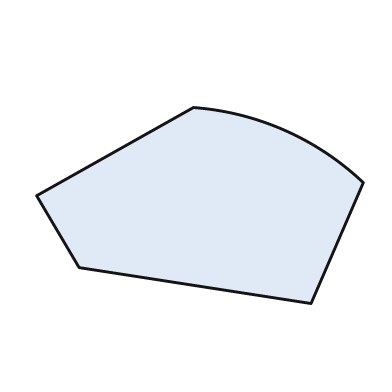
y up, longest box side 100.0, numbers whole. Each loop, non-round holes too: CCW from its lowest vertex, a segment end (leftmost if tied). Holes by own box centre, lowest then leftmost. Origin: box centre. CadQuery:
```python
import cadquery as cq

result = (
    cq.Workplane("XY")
    .moveTo(34.0, -30.0)
    .lineTo(50.0, 7.0)
    .threePointArc((26.0, 23.0), (-2.0, 30.0))
    .lineTo(-50.0, 3.0)
    .lineTo(-37.0, -19.0)
    .close()
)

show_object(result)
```